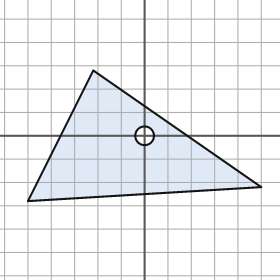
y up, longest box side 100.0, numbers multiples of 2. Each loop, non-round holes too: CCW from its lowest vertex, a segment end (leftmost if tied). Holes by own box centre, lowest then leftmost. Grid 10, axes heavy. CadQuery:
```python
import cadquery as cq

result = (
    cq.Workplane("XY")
    .moveTo(-50.0, -28.0)
    .lineTo(50.0, -22.0)
    .lineTo(-22.0, 28.0)
    .close()
    .moveTo(0.0, 0.0)
    .circle(4.0)
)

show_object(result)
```